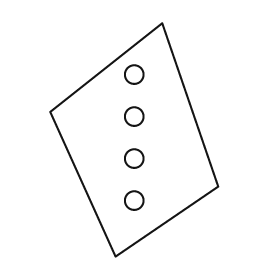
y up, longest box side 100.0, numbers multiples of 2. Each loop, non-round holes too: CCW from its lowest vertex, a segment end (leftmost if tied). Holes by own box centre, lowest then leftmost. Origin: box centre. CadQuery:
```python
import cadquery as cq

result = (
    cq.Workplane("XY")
    .moveTo(-8.0, -50.0)
    .lineTo(36.0, -20.0)
    .lineTo(12.0, 50.0)
    .lineTo(-36.0, 12.0)
    .close()
    .moveTo(0.0, -26.0)
    .circle(4.0)
    .moveTo(0.0, -8.0)
    .circle(4.0)
    .moveTo(0.0, 10.0)
    .circle(4.0)
    .moveTo(0.0, 28.0)
    .circle(4.0)
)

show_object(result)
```